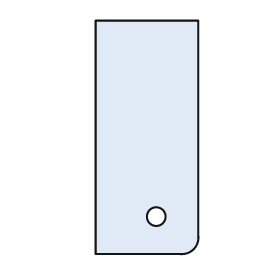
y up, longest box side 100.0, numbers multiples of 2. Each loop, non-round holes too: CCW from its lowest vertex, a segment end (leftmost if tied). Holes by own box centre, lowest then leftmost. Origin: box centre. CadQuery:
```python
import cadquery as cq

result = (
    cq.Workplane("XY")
    .moveTo(-22.0, -50.0)
    .lineTo(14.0, -50.0)
    .threePointArc((20.0, -48.0), (22.0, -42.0))
    .lineTo(22.0, 50.0)
    .lineTo(-22.0, 50.0)
    .close()
    .moveTo(4.0, -34.0)
    .circle(4.0)
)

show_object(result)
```